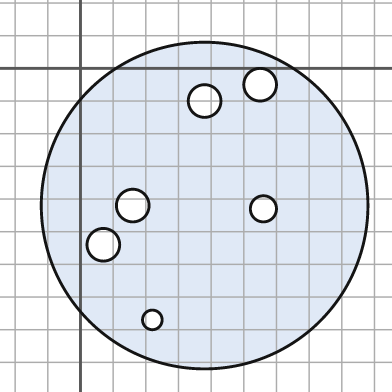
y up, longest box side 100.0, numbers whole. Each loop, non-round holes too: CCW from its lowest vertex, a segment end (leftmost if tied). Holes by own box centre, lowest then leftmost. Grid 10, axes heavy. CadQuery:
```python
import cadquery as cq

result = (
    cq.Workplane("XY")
    .moveTo(38.0, -42.0)
    .circle(50.0)
    .moveTo(22.0, -77.0)
    .circle(3.0)
    .moveTo(7.0, -54.0)
    .circle(5.0)
    .moveTo(56.0, -43.0)
    .circle(4.0)
    .moveTo(16.0, -42.0)
    .circle(5.0)
    .moveTo(38.0, -10.0)
    .circle(5.0)
    .moveTo(55.0, -5.0)
    .circle(5.0)
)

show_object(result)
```